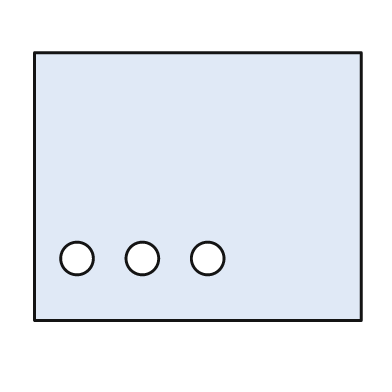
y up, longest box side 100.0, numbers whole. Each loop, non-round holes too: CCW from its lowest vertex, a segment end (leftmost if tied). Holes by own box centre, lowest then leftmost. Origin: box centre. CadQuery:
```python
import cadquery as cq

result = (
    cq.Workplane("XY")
    .moveTo(-50.0, -41.0)
    .lineTo(50.0, -41.0)
    .lineTo(50.0, 41.0)
    .lineTo(-50.0, 41.0)
    .close()
    .moveTo(-37.0, -22.0)
    .circle(5.0)
    .moveTo(-17.0, -22.0)
    .circle(5.0)
    .moveTo(3.0, -22.0)
    .circle(5.0)
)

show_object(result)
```